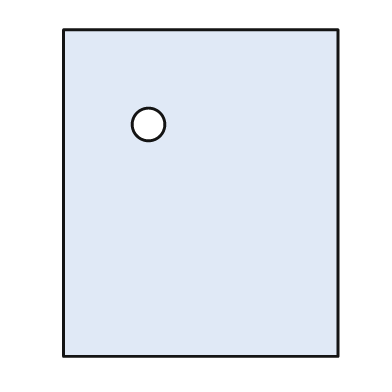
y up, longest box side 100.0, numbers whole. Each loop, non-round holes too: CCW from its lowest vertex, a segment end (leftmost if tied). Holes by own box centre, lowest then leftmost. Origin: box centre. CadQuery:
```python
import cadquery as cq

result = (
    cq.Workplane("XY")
    .moveTo(-42.0, -50.0)
    .lineTo(42.0, -50.0)
    .lineTo(42.0, 50.0)
    .lineTo(-42.0, 50.0)
    .close()
    .moveTo(-16.0, 21.0)
    .circle(5.0)
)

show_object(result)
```